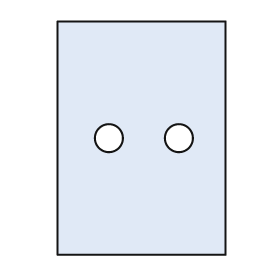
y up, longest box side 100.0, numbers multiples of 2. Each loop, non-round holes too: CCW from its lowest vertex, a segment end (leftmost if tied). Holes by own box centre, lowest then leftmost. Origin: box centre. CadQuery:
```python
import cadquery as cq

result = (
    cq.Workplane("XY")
    .moveTo(-36.0, -50.0)
    .lineTo(36.0, -50.0)
    .lineTo(36.0, 50.0)
    .lineTo(-36.0, 50.0)
    .close()
    .moveTo(-14.0, 0.0)
    .circle(6.0)
    .moveTo(16.0, 0.0)
    .circle(6.0)
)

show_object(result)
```